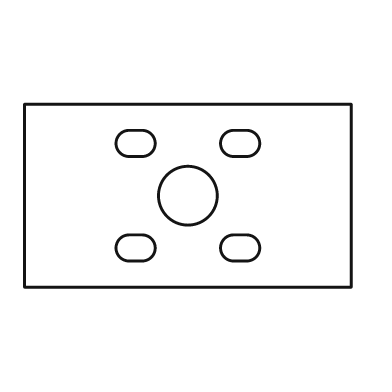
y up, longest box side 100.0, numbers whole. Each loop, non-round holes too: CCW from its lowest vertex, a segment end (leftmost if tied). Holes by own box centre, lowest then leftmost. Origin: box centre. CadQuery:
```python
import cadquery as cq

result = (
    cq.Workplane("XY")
    .moveTo(-50.0, -28.0)
    .lineTo(50.0, -28.0)
    .lineTo(50.0, 28.0)
    .lineTo(-50.0, 28.0)
    .close()
    .moveTo(-18.0, -20.0)
    .lineTo(-14.0, -20.0)
    .threePointArc((-10.0, -16.0), (-14.0, -12.0))
    .lineTo(-18.0, -12.0)
    .threePointArc((-22.0, -16.0), (-18.0, -20.0))
    .close()
    .moveTo(14.0, -20.0)
    .lineTo(18.0, -20.0)
    .threePointArc((22.0, -16.0), (18.0, -12.0))
    .lineTo(14.0, -12.0)
    .threePointArc((10.0, -16.0), (14.0, -20.0))
    .close()
    .moveTo(0.0, 0.0)
    .circle(9.0)
    .moveTo(-18.0, 12.0)
    .lineTo(-14.0, 12.0)
    .threePointArc((-10.0, 16.0), (-14.0, 20.0))
    .lineTo(-18.0, 20.0)
    .threePointArc((-22.0, 16.0), (-18.0, 12.0))
    .close()
    .moveTo(14.0, 12.0)
    .lineTo(18.0, 12.0)
    .threePointArc((22.0, 16.0), (18.0, 20.0))
    .lineTo(14.0, 20.0)
    .threePointArc((10.0, 16.0), (14.0, 12.0))
    .close()
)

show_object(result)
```